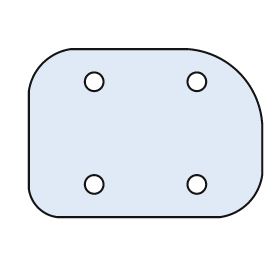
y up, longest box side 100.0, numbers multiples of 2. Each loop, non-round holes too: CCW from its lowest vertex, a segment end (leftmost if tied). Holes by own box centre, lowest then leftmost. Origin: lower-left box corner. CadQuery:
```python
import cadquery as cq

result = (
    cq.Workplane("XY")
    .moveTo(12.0, 0.0)
    .lineTo(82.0, 0.0)
    .threePointArc((94.0, 6.0), (100.0, 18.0))
    .lineTo(100.0, 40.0)
    .threePointArc((90.0, 62.0), (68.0, 72.0))
    .lineTo(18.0, 72.0)
    .threePointArc((6.0, 66.0), (0.0, 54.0))
    .lineTo(0.0, 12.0)
    .threePointArc((4.0, 4.0), (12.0, 0.0))
    .close()
    .moveTo(28.0, 14.0)
    .circle(4.0)
    .moveTo(72.0, 14.0)
    .circle(4.0)
    .moveTo(28.0, 58.0)
    .circle(4.0)
    .moveTo(72.0, 58.0)
    .circle(4.0)
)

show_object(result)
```